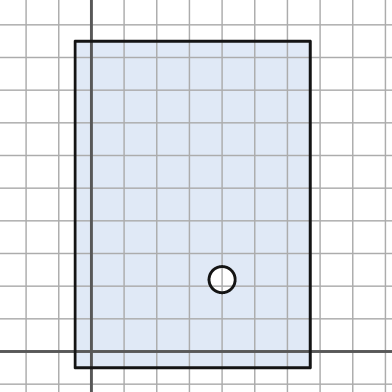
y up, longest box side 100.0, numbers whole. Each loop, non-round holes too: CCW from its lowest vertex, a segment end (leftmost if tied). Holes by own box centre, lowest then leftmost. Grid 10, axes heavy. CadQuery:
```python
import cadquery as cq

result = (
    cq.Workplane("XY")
    .moveTo(-5.0, -5.0)
    .lineTo(67.0, -5.0)
    .lineTo(67.0, 95.0)
    .lineTo(-5.0, 95.0)
    .close()
    .moveTo(40.0, 22.0)
    .circle(4.0)
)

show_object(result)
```